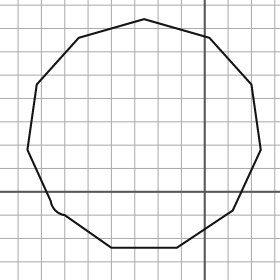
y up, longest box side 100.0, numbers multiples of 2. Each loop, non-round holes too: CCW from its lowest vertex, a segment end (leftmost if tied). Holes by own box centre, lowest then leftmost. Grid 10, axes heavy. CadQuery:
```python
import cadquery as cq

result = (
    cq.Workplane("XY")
    .moveTo(-40.0, -24.0)
    .lineTo(-12.0, -24.0)
    .lineTo(12.0, -8.0)
    .lineTo(24.0, 18.0)
    .lineTo(20.0, 46.0)
    .lineTo(2.0, 66.0)
    .lineTo(-26.0, 74.0)
    .lineTo(-54.0, 66.0)
    .lineTo(-72.0, 46.0)
    .lineTo(-76.0, 18.0)
    .lineTo(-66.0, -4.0)
    .threePointArc((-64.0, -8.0), (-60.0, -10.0))
    .close()
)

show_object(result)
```